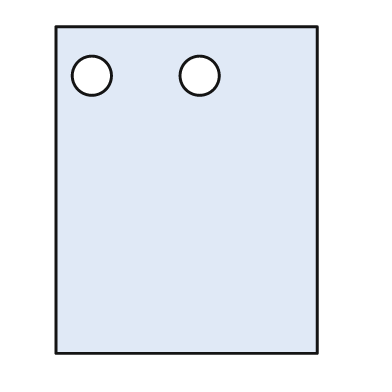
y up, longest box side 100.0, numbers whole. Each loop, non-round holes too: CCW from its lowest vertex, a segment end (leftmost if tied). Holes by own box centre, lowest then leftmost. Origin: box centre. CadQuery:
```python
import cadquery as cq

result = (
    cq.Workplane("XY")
    .moveTo(-40.0, -50.0)
    .lineTo(40.0, -50.0)
    .lineTo(40.0, 50.0)
    .lineTo(-40.0, 50.0)
    .close()
    .moveTo(-29.0, 35.0)
    .circle(6.0)
    .moveTo(4.0, 35.0)
    .circle(6.0)
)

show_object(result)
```